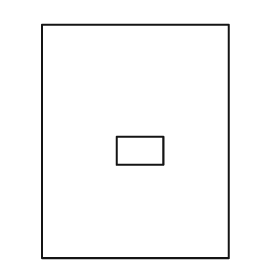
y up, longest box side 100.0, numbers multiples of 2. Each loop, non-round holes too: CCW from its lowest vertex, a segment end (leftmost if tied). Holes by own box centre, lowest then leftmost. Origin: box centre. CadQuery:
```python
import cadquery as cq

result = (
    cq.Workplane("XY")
    .moveTo(-40.0, -50.0)
    .lineTo(40.0, -50.0)
    .lineTo(40.0, 50.0)
    .lineTo(-40.0, 50.0)
    .close()
    .moveTo(-8.0, -10.0)
    .lineTo(12.0, -10.0)
    .lineTo(12.0, 2.0)
    .lineTo(-8.0, 2.0)
    .close()
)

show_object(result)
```